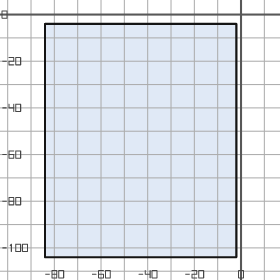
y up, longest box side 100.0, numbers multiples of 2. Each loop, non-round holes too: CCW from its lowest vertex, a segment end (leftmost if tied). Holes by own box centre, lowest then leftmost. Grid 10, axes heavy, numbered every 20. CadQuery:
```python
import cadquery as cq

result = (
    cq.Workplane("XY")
    .moveTo(-84.0, -104.0)
    .lineTo(-2.0, -104.0)
    .lineTo(-2.0, -4.0)
    .lineTo(-84.0, -4.0)
    .close()
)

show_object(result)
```